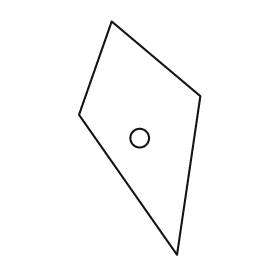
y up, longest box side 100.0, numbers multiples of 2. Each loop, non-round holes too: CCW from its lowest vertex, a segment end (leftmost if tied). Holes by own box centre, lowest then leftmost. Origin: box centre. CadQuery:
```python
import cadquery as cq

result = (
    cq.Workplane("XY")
    .moveTo(16.0, -50.0)
    .lineTo(26.0, 18.0)
    .lineTo(-12.0, 50.0)
    .lineTo(-26.0, 10.0)
    .close()
    .moveTo(0.0, 0.0)
    .circle(4.0)
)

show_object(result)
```